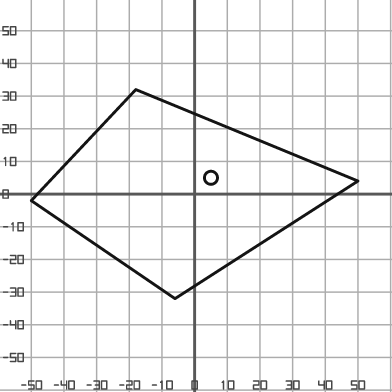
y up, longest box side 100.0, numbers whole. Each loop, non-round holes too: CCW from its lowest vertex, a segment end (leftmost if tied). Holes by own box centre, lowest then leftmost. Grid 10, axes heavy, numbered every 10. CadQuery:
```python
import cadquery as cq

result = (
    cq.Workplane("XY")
    .moveTo(-6.0, -32.0)
    .lineTo(50.0, 4.0)
    .lineTo(-18.0, 32.0)
    .lineTo(-50.0, -2.0)
    .close()
    .moveTo(5.0, 5.0)
    .circle(2.0)
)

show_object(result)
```